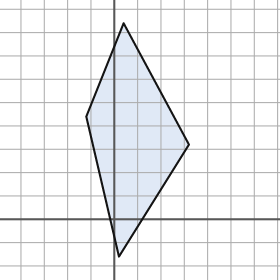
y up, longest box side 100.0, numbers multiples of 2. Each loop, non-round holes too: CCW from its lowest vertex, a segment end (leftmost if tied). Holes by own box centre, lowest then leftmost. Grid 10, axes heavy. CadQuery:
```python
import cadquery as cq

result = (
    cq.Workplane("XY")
    .moveTo(2.0, -16.0)
    .lineTo(32.0, 32.0)
    .lineTo(4.0, 84.0)
    .lineTo(-12.0, 44.0)
    .close()
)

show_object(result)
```